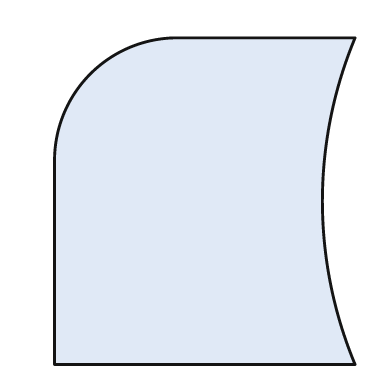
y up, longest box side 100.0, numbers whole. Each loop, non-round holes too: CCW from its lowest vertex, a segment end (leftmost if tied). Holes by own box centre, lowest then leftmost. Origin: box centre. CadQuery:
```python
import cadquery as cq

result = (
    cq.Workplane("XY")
    .moveTo(-46.0, -50.0)
    .lineTo(46.0, -50.0)
    .threePointArc((36.0, 0.0), (46.0, 50.0))
    .lineTo(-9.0, 50.0)
    .threePointArc((-35.0, 39.0), (-46.0, 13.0))
    .close()
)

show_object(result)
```